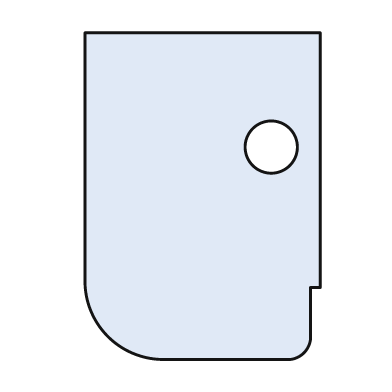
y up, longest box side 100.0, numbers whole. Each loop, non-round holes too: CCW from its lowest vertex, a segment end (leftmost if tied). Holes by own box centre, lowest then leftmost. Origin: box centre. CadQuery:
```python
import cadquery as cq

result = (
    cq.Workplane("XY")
    .moveTo(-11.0, -50.0)
    .lineTo(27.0, -50.0)
    .threePointArc((31.0, -48.0), (33.0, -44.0))
    .lineTo(33.0, -28.0)
    .lineTo(36.0, -28.0)
    .lineTo(36.0, 50.0)
    .lineTo(-36.0, 50.0)
    .lineTo(-36.0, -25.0)
    .threePointArc((-29.0, -43.0), (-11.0, -50.0))
    .close()
    .moveTo(21.0, 15.0)
    .circle(8.0)
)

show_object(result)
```